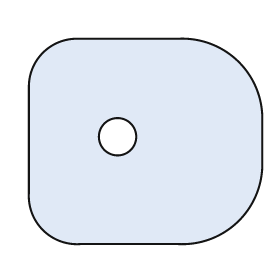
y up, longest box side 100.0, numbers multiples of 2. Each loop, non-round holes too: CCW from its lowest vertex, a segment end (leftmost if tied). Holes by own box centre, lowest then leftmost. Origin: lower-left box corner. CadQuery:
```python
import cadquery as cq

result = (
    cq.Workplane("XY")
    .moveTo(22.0, 0.0)
    .lineTo(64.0, 0.0)
    .threePointArc((90.0, 10.0), (100.0, 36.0))
    .lineTo(100.0, 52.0)
    .threePointArc((90.0, 78.0), (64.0, 88.0))
    .lineTo(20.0, 88.0)
    .threePointArc((6.0, 82.0), (0.0, 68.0))
    .lineTo(0.0, 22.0)
    .threePointArc((6.0, 6.0), (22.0, 0.0))
    .close()
    .moveTo(38.0, 46.0)
    .circle(8.0)
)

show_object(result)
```